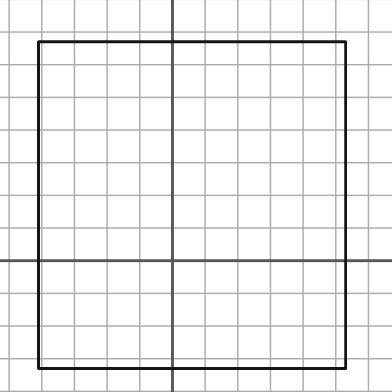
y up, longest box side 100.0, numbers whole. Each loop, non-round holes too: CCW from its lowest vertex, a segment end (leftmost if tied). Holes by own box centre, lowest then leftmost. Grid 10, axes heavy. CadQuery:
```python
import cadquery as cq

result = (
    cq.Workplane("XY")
    .moveTo(-41.0, -33.0)
    .lineTo(53.0, -33.0)
    .lineTo(53.0, 67.0)
    .lineTo(-41.0, 67.0)
    .close()
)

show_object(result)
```